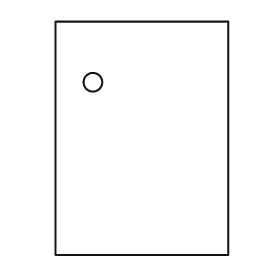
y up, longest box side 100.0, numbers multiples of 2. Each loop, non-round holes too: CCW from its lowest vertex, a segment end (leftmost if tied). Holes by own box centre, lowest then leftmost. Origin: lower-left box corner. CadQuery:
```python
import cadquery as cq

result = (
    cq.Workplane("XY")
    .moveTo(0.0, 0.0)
    .lineTo(74.0, 0.0)
    .lineTo(74.0, 100.0)
    .lineTo(0.0, 100.0)
    .close()
    .moveTo(16.0, 74.0)
    .circle(4.0)
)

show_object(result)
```